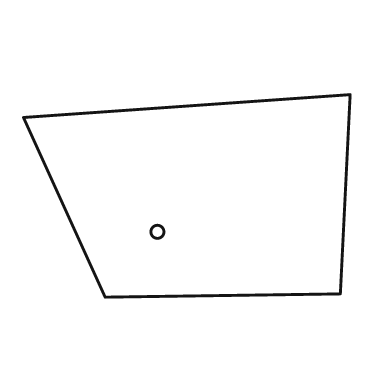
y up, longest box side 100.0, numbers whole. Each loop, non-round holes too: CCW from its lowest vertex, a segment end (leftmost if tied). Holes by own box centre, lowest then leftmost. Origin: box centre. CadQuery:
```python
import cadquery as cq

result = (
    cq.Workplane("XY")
    .moveTo(-25.0, -31.0)
    .lineTo(47.0, -30.0)
    .lineTo(50.0, 31.0)
    .lineTo(-50.0, 24.0)
    .close()
    .moveTo(-9.0, -11.0)
    .circle(2.0)
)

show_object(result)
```